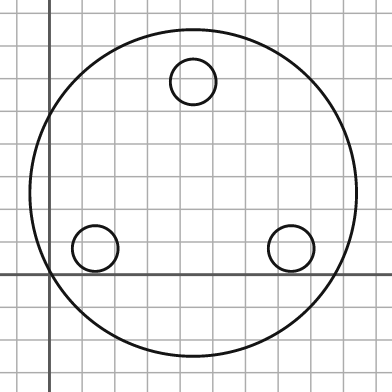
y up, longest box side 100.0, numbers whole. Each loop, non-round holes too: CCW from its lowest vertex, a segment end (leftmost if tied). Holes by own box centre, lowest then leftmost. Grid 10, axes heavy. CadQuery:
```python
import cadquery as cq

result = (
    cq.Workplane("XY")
    .moveTo(44.0, 25.0)
    .circle(50.0)
    .moveTo(14.0, 8.0)
    .circle(7.0)
    .moveTo(74.0, 8.0)
    .circle(7.0)
    .moveTo(44.0, 59.0)
    .circle(7.0)
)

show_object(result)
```